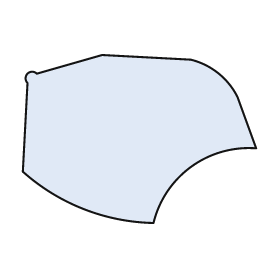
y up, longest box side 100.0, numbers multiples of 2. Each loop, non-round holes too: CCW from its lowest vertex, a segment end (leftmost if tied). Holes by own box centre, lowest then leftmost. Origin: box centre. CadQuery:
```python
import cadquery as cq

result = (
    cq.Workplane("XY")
    .moveTo(6.0, -36.0)
    .threePointArc((22.0, -12.0), (50.0, -4.0))
    .lineTo(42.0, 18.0)
    .threePointArc((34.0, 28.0), (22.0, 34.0))
    .lineTo(-16.0, 36.0)
    .lineTo(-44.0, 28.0)
    .threePointArc((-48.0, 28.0), (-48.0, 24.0))
    .lineTo(-50.0, -14.0)
    .threePointArc((-24.0, -30.0), (6.0, -36.0))
    .close()
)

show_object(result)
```